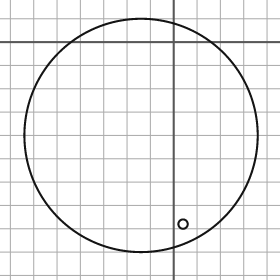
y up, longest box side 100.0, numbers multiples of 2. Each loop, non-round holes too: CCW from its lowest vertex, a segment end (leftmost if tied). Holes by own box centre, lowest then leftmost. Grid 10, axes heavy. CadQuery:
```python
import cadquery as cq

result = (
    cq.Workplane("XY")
    .moveTo(-14.0, -40.0)
    .circle(50.0)
    .moveTo(4.0, -78.0)
    .circle(2.0)
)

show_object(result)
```